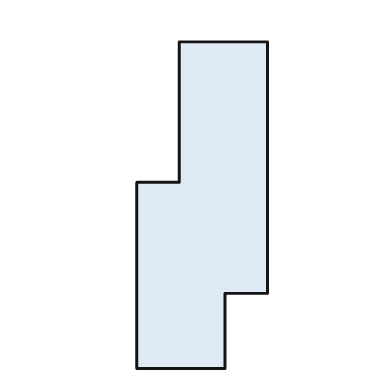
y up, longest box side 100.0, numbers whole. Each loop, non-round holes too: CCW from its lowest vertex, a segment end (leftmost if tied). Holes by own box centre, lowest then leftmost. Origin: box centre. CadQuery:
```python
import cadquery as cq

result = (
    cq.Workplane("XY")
    .moveTo(-20.0, -50.0)
    .lineTo(7.0, -50.0)
    .lineTo(7.0, -27.0)
    .lineTo(20.0, -27.0)
    .lineTo(20.0, 50.0)
    .lineTo(-7.0, 50.0)
    .lineTo(-7.0, 7.0)
    .lineTo(-20.0, 7.0)
    .close()
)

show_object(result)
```